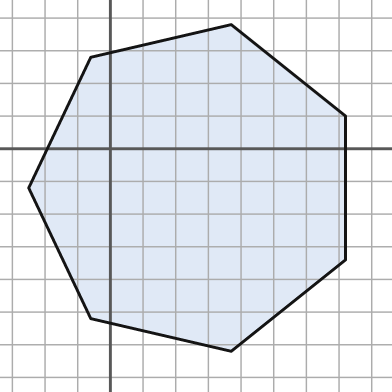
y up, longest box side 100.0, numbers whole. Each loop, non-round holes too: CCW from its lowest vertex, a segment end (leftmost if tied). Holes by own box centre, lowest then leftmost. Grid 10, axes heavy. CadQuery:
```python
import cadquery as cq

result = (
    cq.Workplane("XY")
    .moveTo(37.0, -62.0)
    .lineTo(72.0, -34.0)
    .lineTo(72.0, 10.0)
    .lineTo(37.0, 38.0)
    .lineTo(-6.0, 28.0)
    .lineTo(-25.0, -12.0)
    .lineTo(-6.0, -52.0)
    .close()
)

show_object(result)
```